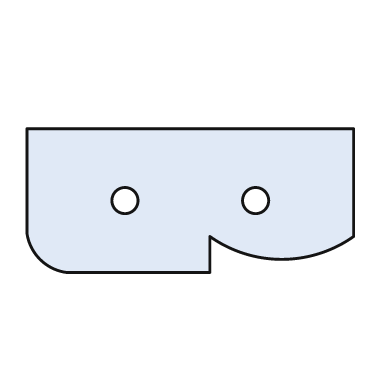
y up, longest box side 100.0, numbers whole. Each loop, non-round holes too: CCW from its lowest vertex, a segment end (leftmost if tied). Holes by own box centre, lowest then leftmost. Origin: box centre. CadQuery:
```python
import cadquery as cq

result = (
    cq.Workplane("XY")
    .moveTo(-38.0, -22.0)
    .lineTo(6.0, -22.0)
    .lineTo(6.0, -11.0)
    .threePointArc((28.0, -18.0), (50.0, -11.0))
    .lineTo(50.0, 22.0)
    .lineTo(-50.0, 22.0)
    .lineTo(-50.0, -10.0)
    .threePointArc((-46.0, -18.0), (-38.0, -22.0))
    .close()
    .moveTo(-20.0, 0.0)
    .circle(4.0)
    .moveTo(20.0, 0.0)
    .circle(4.0)
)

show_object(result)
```